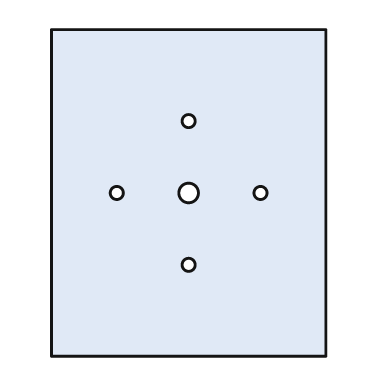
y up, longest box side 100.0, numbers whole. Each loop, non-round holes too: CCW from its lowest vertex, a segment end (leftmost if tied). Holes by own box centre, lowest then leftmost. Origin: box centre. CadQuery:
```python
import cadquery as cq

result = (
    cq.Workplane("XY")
    .moveTo(-42.0, -50.0)
    .lineTo(42.0, -50.0)
    .lineTo(42.0, 50.0)
    .lineTo(-42.0, 50.0)
    .close()
    .moveTo(0.0, -22.0)
    .circle(2.0)
    .moveTo(-22.0, 0.0)
    .circle(2.0)
    .moveTo(0.0, 0.0)
    .circle(3.0)
    .moveTo(22.0, 0.0)
    .circle(2.0)
    .moveTo(0.0, 22.0)
    .circle(2.0)
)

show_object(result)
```